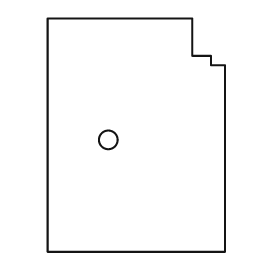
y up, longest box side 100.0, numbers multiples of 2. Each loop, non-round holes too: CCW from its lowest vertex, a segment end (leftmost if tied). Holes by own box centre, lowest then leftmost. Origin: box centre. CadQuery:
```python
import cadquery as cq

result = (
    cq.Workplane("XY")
    .moveTo(-38.0, -50.0)
    .lineTo(38.0, -50.0)
    .lineTo(38.0, 30.0)
    .lineTo(32.0, 30.0)
    .lineTo(32.0, 34.0)
    .lineTo(24.0, 34.0)
    .lineTo(24.0, 50.0)
    .lineTo(-38.0, 50.0)
    .close()
    .moveTo(-12.0, -2.0)
    .circle(4.0)
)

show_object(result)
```